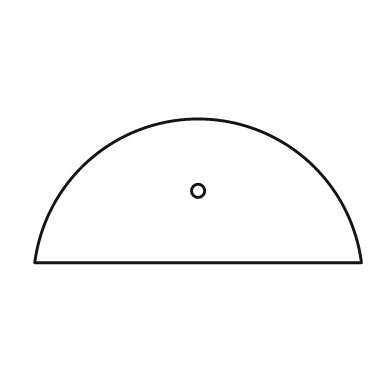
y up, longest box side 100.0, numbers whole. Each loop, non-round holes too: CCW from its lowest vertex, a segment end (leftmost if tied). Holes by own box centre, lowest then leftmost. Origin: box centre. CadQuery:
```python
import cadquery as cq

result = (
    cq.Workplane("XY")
    .moveTo(-50.0, -22.0)
    .lineTo(50.0, -22.0)
    .threePointArc((0.0, 22.0), (-50.0, -22.0))
    .close()
    .moveTo(0.0, 0.0)
    .circle(2.0)
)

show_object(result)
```